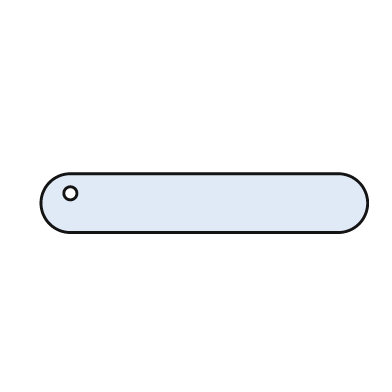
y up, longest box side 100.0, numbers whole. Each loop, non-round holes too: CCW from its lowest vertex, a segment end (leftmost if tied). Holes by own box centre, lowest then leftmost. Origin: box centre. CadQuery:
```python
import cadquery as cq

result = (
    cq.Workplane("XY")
    .moveTo(-41.0, -9.0)
    .lineTo(41.0, -9.0)
    .threePointArc((50.0, 0.0), (41.0, 9.0))
    .lineTo(-41.0, 9.0)
    .threePointArc((-50.0, 0.0), (-41.0, -9.0))
    .close()
    .moveTo(-41.0, 3.0)
    .circle(2.0)
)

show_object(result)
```